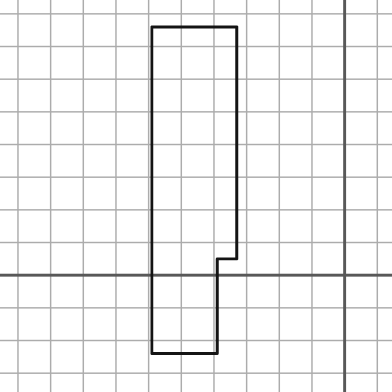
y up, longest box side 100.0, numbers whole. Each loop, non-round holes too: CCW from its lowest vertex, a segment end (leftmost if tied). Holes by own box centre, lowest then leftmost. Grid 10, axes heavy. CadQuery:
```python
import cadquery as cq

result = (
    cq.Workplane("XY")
    .moveTo(-59.0, -24.0)
    .lineTo(-39.0, -24.0)
    .lineTo(-39.0, 5.0)
    .lineTo(-33.0, 5.0)
    .lineTo(-33.0, 76.0)
    .lineTo(-59.0, 76.0)
    .close()
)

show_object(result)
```